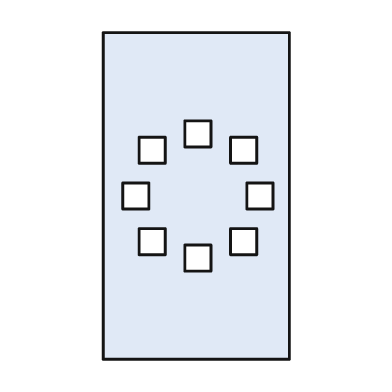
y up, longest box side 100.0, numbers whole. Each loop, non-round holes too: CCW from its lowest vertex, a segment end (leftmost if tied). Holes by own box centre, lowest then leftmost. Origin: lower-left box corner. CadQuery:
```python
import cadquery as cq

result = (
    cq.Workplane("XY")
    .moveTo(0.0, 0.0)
    .lineTo(57.0, 0.0)
    .lineTo(57.0, 100.0)
    .lineTo(0.0, 100.0)
    .close()
    .moveTo(25.0, 27.0)
    .lineTo(33.0, 27.0)
    .lineTo(33.0, 35.0)
    .lineTo(25.0, 35.0)
    .close()
    .moveTo(11.0, 32.0)
    .lineTo(19.0, 32.0)
    .lineTo(19.0, 40.0)
    .lineTo(11.0, 40.0)
    .close()
    .moveTo(39.0, 32.0)
    .lineTo(47.0, 32.0)
    .lineTo(47.0, 40.0)
    .lineTo(39.0, 40.0)
    .close()
    .moveTo(6.0, 46.0)
    .lineTo(14.0, 46.0)
    .lineTo(14.0, 54.0)
    .lineTo(6.0, 54.0)
    .close()
    .moveTo(44.0, 46.0)
    .lineTo(52.0, 46.0)
    .lineTo(52.0, 54.0)
    .lineTo(44.0, 54.0)
    .close()
    .moveTo(11.0, 60.0)
    .lineTo(19.0, 60.0)
    .lineTo(19.0, 68.0)
    .lineTo(11.0, 68.0)
    .close()
    .moveTo(39.0, 60.0)
    .lineTo(47.0, 60.0)
    .lineTo(47.0, 68.0)
    .lineTo(39.0, 68.0)
    .close()
    .moveTo(25.0, 65.0)
    .lineTo(33.0, 65.0)
    .lineTo(33.0, 73.0)
    .lineTo(25.0, 73.0)
    .close()
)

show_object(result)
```